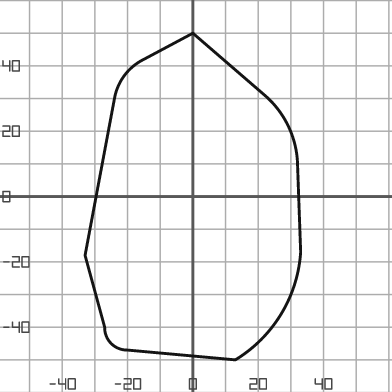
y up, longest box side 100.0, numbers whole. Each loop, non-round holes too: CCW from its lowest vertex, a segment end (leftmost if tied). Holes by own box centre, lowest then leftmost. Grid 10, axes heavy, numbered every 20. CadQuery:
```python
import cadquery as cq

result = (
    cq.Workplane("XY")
    .moveTo(13.0, -50.0)
    .threePointArc((27.0, -36.0), (33.0, -17.0))
    .lineTo(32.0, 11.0)
    .threePointArc((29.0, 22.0), (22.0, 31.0))
    .lineTo(0.0, 50.0)
    .lineTo(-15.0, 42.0)
    .threePointArc((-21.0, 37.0), (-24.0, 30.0))
    .lineTo(-33.0, -18.0)
    .lineTo(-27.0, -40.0)
    .threePointArc((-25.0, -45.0), (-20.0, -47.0))
    .close()
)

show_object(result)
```